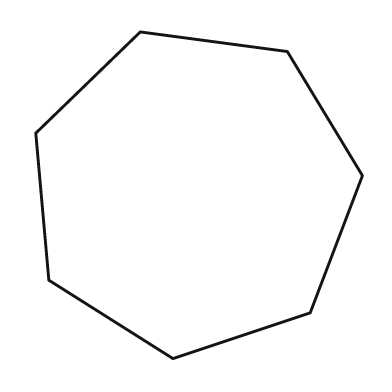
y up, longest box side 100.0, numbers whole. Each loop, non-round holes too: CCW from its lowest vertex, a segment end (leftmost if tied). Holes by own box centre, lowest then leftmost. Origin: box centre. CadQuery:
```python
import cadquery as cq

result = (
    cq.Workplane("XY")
    .moveTo(-8.0, -50.0)
    .lineTo(34.0, -36.0)
    .lineTo(50.0, 6.0)
    .lineTo(27.0, 44.0)
    .lineTo(-18.0, 50.0)
    .lineTo(-50.0, 19.0)
    .lineTo(-46.0, -26.0)
    .close()
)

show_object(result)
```